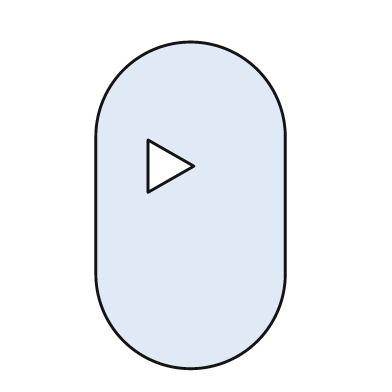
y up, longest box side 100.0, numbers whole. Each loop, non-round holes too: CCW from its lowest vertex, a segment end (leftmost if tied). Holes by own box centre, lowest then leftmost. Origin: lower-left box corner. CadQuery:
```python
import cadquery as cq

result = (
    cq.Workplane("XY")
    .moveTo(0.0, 29.0)
    .threePointArc((29.0, 0.0), (58.0, 29.0))
    .lineTo(58.0, 71.0)
    .threePointArc((29.0, 100.0), (0.0, 71.0))
    .close()
    .moveTo(16.0, 54.0)
    .lineTo(30.0, 62.0)
    .lineTo(16.0, 70.0)
    .close()
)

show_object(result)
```